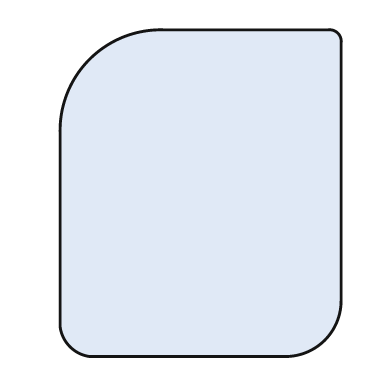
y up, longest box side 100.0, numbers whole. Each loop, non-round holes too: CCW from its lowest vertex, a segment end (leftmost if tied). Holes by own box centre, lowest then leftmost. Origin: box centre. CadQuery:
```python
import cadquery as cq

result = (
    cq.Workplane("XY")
    .moveTo(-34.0, -50.0)
    .lineTo(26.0, -50.0)
    .threePointArc((38.0, -45.0), (43.0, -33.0))
    .lineTo(43.0, 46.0)
    .threePointArc((42.0, 49.0), (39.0, 50.0))
    .lineTo(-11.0, 50.0)
    .threePointArc((-34.0, 41.0), (-43.0, 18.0))
    .lineTo(-43.0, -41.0)
    .threePointArc((-40.0, -47.0), (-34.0, -50.0))
    .close()
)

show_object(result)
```